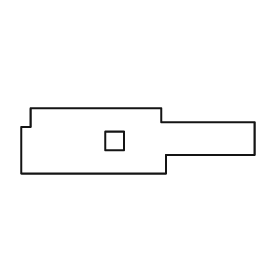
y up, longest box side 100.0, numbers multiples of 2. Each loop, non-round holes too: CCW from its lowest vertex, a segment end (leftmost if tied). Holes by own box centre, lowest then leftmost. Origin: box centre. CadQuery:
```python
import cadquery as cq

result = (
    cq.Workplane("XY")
    .moveTo(-50.0, -14.0)
    .lineTo(12.0, -14.0)
    .lineTo(12.0, -6.0)
    .lineTo(50.0, -6.0)
    .lineTo(50.0, 8.0)
    .lineTo(10.0, 8.0)
    .lineTo(10.0, 14.0)
    .lineTo(-46.0, 14.0)
    .lineTo(-46.0, 6.0)
    .lineTo(-50.0, 6.0)
    .close()
    .moveTo(-14.0, -4.0)
    .lineTo(-6.0, -4.0)
    .lineTo(-6.0, 4.0)
    .lineTo(-14.0, 4.0)
    .close()
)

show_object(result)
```